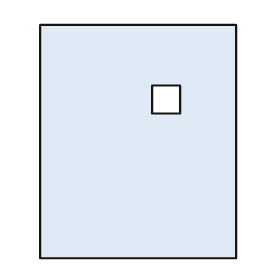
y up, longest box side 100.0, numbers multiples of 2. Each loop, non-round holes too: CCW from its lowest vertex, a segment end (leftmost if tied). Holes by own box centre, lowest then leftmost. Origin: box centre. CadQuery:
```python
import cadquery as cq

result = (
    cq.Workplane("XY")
    .moveTo(-42.0, -50.0)
    .lineTo(42.0, -50.0)
    .lineTo(42.0, 50.0)
    .lineTo(-42.0, 50.0)
    .close()
    .moveTo(6.0, 12.0)
    .lineTo(18.0, 12.0)
    .lineTo(18.0, 24.0)
    .lineTo(6.0, 24.0)
    .close()
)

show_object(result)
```